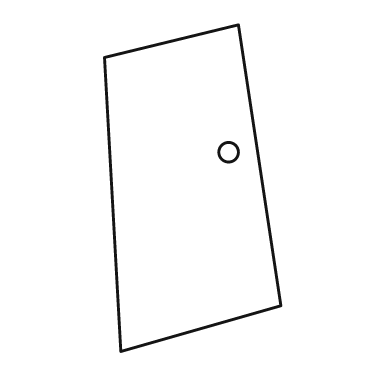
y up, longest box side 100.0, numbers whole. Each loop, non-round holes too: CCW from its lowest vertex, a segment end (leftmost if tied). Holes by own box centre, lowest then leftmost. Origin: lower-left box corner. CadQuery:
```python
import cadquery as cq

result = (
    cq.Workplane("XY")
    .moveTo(5.0, 0.0)
    .lineTo(54.0, 14.0)
    .lineTo(41.0, 100.0)
    .lineTo(0.0, 90.0)
    .close()
    .moveTo(38.0, 61.0)
    .circle(3.0)
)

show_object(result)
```